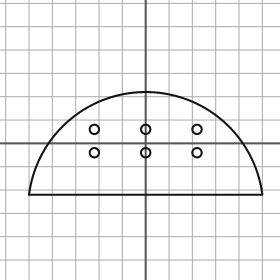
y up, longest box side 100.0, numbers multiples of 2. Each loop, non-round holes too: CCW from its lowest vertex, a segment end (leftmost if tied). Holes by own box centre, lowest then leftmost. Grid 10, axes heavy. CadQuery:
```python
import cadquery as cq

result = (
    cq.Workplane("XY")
    .moveTo(-50.0, -22.0)
    .lineTo(50.0, -22.0)
    .threePointArc((0.0, 22.0), (-50.0, -22.0))
    .close()
    .moveTo(-22.0, -4.0)
    .circle(2.0)
    .moveTo(0.0, -4.0)
    .circle(2.0)
    .moveTo(22.0, -4.0)
    .circle(2.0)
    .moveTo(-22.0, 6.0)
    .circle(2.0)
    .moveTo(0.0, 6.0)
    .circle(2.0)
    .moveTo(22.0, 6.0)
    .circle(2.0)
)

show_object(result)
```